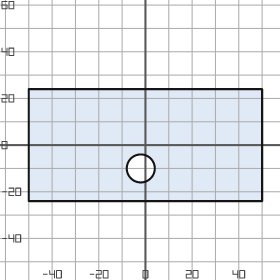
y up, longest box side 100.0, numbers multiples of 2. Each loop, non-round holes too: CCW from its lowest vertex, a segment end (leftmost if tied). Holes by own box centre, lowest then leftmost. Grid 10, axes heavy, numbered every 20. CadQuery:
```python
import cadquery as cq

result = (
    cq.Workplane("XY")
    .moveTo(-50.0, -24.0)
    .lineTo(50.0, -24.0)
    .lineTo(50.0, 24.0)
    .lineTo(-50.0, 24.0)
    .close()
    .moveTo(-2.0, -10.0)
    .circle(6.0)
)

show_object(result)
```